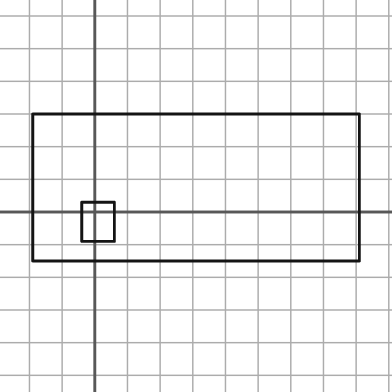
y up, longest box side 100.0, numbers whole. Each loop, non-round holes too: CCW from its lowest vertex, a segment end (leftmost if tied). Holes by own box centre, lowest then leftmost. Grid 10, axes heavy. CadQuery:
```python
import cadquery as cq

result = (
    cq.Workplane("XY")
    .moveTo(-19.0, -15.0)
    .lineTo(81.0, -15.0)
    .lineTo(81.0, 30.0)
    .lineTo(-19.0, 30.0)
    .close()
    .moveTo(-4.0, -9.0)
    .lineTo(6.0, -9.0)
    .lineTo(6.0, 3.0)
    .lineTo(-4.0, 3.0)
    .close()
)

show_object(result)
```